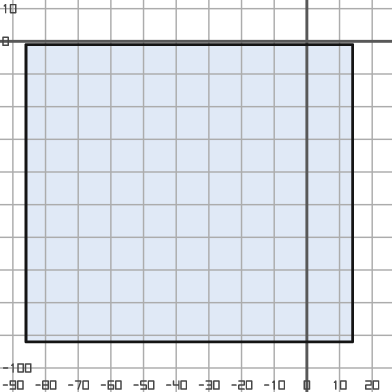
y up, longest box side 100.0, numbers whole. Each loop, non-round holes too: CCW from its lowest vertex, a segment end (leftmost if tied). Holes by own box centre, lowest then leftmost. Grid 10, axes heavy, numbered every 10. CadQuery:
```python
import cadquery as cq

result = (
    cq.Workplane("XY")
    .moveTo(-86.0, -92.0)
    .lineTo(14.0, -92.0)
    .lineTo(14.0, -1.0)
    .lineTo(-86.0, -1.0)
    .close()
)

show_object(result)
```